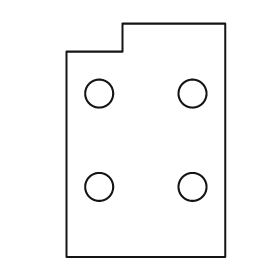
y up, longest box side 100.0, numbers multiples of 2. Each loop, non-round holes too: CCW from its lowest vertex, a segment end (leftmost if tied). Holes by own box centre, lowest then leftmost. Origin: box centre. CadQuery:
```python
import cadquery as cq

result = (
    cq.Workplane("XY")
    .moveTo(-34.0, -50.0)
    .lineTo(34.0, -50.0)
    .lineTo(34.0, 50.0)
    .lineTo(-10.0, 50.0)
    .lineTo(-10.0, 38.0)
    .lineTo(-34.0, 38.0)
    .close()
    .moveTo(-20.0, -20.0)
    .circle(6.0)
    .moveTo(20.0, -20.0)
    .circle(6.0)
    .moveTo(-20.0, 20.0)
    .circle(6.0)
    .moveTo(20.0, 20.0)
    .circle(6.0)
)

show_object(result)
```